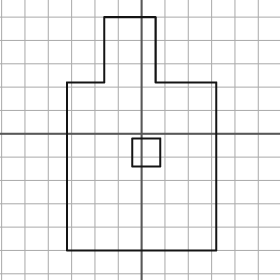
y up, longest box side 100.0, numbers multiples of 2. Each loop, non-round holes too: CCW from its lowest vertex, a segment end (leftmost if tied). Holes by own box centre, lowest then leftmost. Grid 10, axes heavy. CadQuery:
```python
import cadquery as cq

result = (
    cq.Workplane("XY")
    .moveTo(-32.0, -50.0)
    .lineTo(32.0, -50.0)
    .lineTo(32.0, 22.0)
    .lineTo(6.0, 22.0)
    .lineTo(6.0, 50.0)
    .lineTo(-16.0, 50.0)
    .lineTo(-16.0, 22.0)
    .lineTo(-32.0, 22.0)
    .close()
    .moveTo(-4.0, -14.0)
    .lineTo(8.0, -14.0)
    .lineTo(8.0, -2.0)
    .lineTo(-4.0, -2.0)
    .close()
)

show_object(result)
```